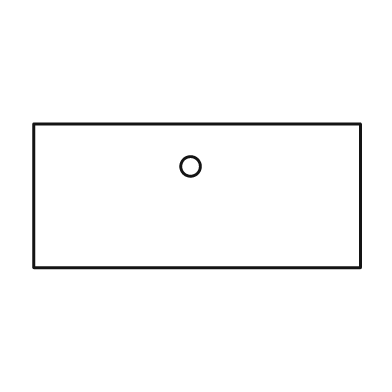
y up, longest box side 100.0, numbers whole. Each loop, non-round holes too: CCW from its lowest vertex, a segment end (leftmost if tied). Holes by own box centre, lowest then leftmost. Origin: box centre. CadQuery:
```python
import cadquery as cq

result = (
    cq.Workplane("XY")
    .moveTo(-50.0, -22.0)
    .lineTo(50.0, -22.0)
    .lineTo(50.0, 22.0)
    .lineTo(-50.0, 22.0)
    .close()
    .moveTo(-2.0, 9.0)
    .circle(3.0)
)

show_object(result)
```